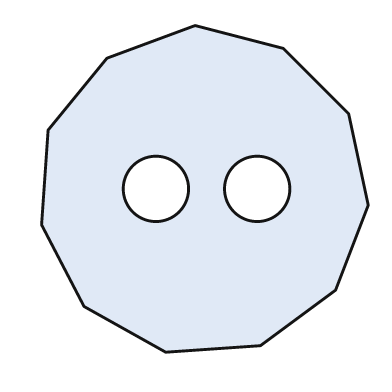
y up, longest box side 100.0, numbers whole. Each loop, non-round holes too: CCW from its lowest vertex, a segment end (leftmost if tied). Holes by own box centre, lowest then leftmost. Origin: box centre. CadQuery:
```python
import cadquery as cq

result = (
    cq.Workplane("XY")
    .moveTo(-12.0, -50.0)
    .lineTo(17.0, -48.0)
    .lineTo(40.0, -31.0)
    .lineTo(50.0, -5.0)
    .lineTo(44.0, 23.0)
    .lineTo(24.0, 43.0)
    .lineTo(-3.0, 50.0)
    .lineTo(-30.0, 40.0)
    .lineTo(-48.0, 18.0)
    .lineTo(-50.0, -11.0)
    .lineTo(-37.0, -36.0)
    .close()
    .moveTo(-15.0, 0.0)
    .circle(10.0)
    .moveTo(16.0, 0.0)
    .circle(10.0)
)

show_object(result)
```